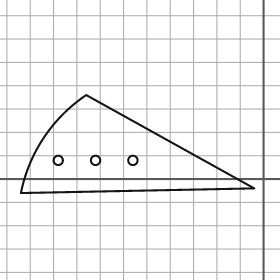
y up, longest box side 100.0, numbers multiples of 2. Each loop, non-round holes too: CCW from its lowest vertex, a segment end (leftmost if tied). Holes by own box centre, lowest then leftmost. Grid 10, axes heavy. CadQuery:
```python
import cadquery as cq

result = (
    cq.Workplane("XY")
    .moveTo(-104.0, -6.0)
    .lineTo(-4.0, -4.0)
    .lineTo(-76.0, 36.0)
    .threePointArc((-94.0, 18.0), (-104.0, -6.0))
    .close()
    .moveTo(-88.0, 8.0)
    .circle(2.0)
    .moveTo(-72.0, 8.0)
    .circle(2.0)
    .moveTo(-56.0, 8.0)
    .circle(2.0)
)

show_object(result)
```